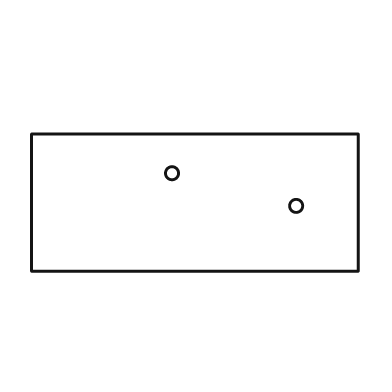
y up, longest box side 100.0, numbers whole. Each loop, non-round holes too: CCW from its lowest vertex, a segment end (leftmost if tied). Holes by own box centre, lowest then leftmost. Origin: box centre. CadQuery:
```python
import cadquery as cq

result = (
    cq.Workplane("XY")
    .moveTo(-50.0, -21.0)
    .lineTo(50.0, -21.0)
    .lineTo(50.0, 21.0)
    .lineTo(-50.0, 21.0)
    .close()
    .moveTo(31.0, -1.0)
    .circle(2.0)
    .moveTo(-7.0, 9.0)
    .circle(2.0)
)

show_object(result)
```